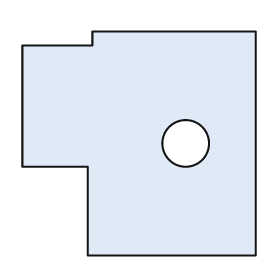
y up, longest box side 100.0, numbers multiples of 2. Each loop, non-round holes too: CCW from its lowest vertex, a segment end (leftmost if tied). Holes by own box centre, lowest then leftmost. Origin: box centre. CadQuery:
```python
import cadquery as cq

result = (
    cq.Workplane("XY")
    .moveTo(-22.0, -48.0)
    .lineTo(50.0, -48.0)
    .lineTo(50.0, 48.0)
    .lineTo(-20.0, 48.0)
    .lineTo(-20.0, 42.0)
    .lineTo(-50.0, 42.0)
    .lineTo(-50.0, -10.0)
    .lineTo(-22.0, -10.0)
    .close()
    .moveTo(20.0, 0.0)
    .circle(10.0)
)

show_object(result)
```